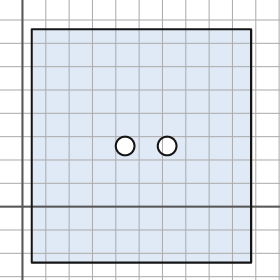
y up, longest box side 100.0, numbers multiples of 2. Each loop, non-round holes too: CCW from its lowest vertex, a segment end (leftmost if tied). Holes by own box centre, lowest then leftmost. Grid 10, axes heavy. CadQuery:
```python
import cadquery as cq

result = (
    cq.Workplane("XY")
    .moveTo(4.0, -24.0)
    .lineTo(98.0, -24.0)
    .lineTo(98.0, 76.0)
    .lineTo(4.0, 76.0)
    .close()
    .moveTo(44.0, 26.0)
    .circle(4.0)
    .moveTo(62.0, 26.0)
    .circle(4.0)
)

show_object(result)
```